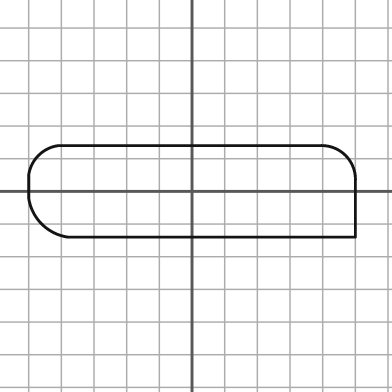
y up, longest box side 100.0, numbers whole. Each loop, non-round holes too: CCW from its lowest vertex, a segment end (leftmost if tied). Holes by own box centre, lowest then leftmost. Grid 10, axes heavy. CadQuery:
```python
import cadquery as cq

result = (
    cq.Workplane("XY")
    .moveTo(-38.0, -14.0)
    .lineTo(50.0, -14.0)
    .lineTo(50.0, 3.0)
    .threePointArc((47.0, 11.0), (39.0, 14.0))
    .lineTo(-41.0, 14.0)
    .threePointArc((-47.0, 11.0), (-50.0, 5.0))
    .lineTo(-50.0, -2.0)
    .threePointArc((-46.0, -10.0), (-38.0, -14.0))
    .close()
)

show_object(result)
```